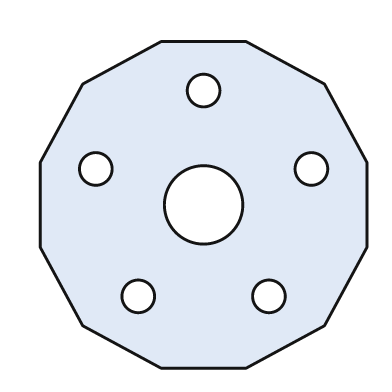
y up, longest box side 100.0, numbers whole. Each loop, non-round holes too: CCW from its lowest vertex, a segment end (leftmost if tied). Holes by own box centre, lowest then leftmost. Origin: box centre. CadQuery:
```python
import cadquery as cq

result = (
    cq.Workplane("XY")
    .moveTo(-13.0, -50.0)
    .lineTo(13.0, -50.0)
    .lineTo(37.0, -37.0)
    .lineTo(50.0, -13.0)
    .lineTo(50.0, 13.0)
    .lineTo(37.0, 37.0)
    .lineTo(13.0, 50.0)
    .lineTo(-13.0, 50.0)
    .lineTo(-37.0, 37.0)
    .lineTo(-50.0, 13.0)
    .lineTo(-50.0, -13.0)
    .lineTo(-37.0, -37.0)
    .close()
    .moveTo(-20.0, -28.0)
    .circle(5.0)
    .moveTo(20.0, -28.0)
    .circle(5.0)
    .moveTo(0.0, 0.0)
    .circle(12.0)
    .moveTo(-33.0, 11.0)
    .circle(5.0)
    .moveTo(33.0, 11.0)
    .circle(5.0)
    .moveTo(0.0, 35.0)
    .circle(5.0)
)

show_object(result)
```